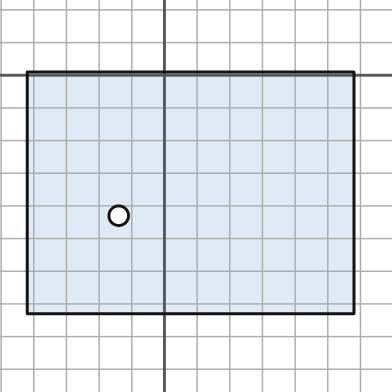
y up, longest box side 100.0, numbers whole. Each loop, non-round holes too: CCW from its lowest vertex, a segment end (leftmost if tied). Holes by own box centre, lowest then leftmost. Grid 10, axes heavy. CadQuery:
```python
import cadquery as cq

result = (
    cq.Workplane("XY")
    .moveTo(-42.0, -73.0)
    .lineTo(58.0, -73.0)
    .lineTo(58.0, 1.0)
    .lineTo(-42.0, 1.0)
    .close()
    .moveTo(-14.0, -43.0)
    .circle(3.0)
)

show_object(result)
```